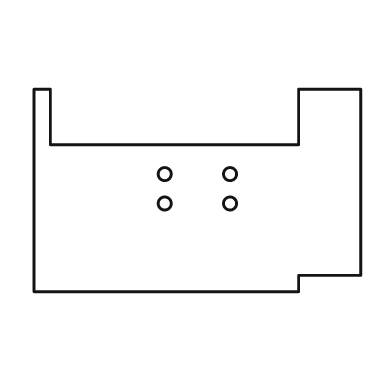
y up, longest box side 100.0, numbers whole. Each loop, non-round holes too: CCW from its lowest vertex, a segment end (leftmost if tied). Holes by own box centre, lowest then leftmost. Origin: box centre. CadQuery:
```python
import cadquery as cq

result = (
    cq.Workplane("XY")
    .moveTo(-50.0, -31.0)
    .lineTo(31.0, -31.0)
    .lineTo(31.0, -26.0)
    .lineTo(50.0, -26.0)
    .lineTo(50.0, 31.0)
    .lineTo(31.0, 31.0)
    .lineTo(31.0, 14.0)
    .lineTo(-45.0, 14.0)
    .lineTo(-45.0, 31.0)
    .lineTo(-50.0, 31.0)
    .close()
    .moveTo(-10.0, -4.0)
    .circle(2.0)
    .moveTo(10.0, -4.0)
    .circle(2.0)
    .moveTo(-10.0, 5.0)
    .circle(2.0)
    .moveTo(10.0, 5.0)
    .circle(2.0)
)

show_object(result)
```